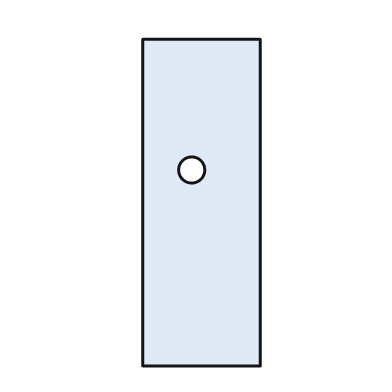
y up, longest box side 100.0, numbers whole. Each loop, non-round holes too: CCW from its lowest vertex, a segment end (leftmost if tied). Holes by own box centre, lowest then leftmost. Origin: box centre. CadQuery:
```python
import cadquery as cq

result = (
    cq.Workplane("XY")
    .moveTo(-18.0, -50.0)
    .lineTo(18.0, -50.0)
    .lineTo(18.0, 50.0)
    .lineTo(-18.0, 50.0)
    .close()
    .moveTo(-3.0, 10.0)
    .circle(4.0)
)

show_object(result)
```